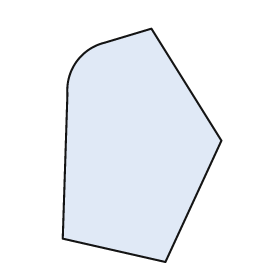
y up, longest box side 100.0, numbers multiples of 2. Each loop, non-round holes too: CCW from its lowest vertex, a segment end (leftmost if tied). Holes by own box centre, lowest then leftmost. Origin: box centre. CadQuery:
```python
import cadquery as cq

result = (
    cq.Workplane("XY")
    .moveTo(10.0, -50.0)
    .lineTo(34.0, 2.0)
    .lineTo(4.0, 50.0)
    .lineTo(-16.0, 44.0)
    .threePointArc((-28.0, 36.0), (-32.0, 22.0))
    .lineTo(-34.0, -40.0)
    .close()
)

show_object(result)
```